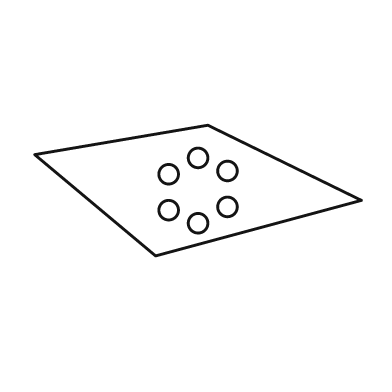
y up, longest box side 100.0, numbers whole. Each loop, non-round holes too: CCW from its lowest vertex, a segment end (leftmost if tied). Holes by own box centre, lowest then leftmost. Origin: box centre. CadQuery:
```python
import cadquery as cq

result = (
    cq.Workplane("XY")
    .moveTo(-13.0, -20.0)
    .lineTo(50.0, -3.0)
    .lineTo(3.0, 20.0)
    .lineTo(-50.0, 11.0)
    .close()
    .moveTo(0.0, -10.0)
    .circle(3.0)
    .moveTo(-9.0, -6.0)
    .circle(3.0)
    .moveTo(9.0, -5.0)
    .circle(3.0)
    .moveTo(-9.0, 5.0)
    .circle(3.0)
    .moveTo(9.0, 6.0)
    .circle(3.0)
    .moveTo(0.0, 10.0)
    .circle(3.0)
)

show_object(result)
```